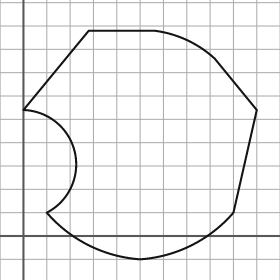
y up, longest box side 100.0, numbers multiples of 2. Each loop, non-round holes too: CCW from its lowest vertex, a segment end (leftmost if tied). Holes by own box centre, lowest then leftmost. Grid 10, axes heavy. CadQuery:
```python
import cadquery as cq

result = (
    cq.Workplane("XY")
    .moveTo(50.0, -10.0)
    .threePointArc((72.0, -4.0), (90.0, 10.0))
    .lineTo(100.0, 54.0)
    .lineTo(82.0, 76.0)
    .threePointArc((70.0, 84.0), (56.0, 88.0))
    .lineTo(28.0, 88.0)
    .lineTo(0.0, 54.0)
    .threePointArc((22.0, 36.0), (10.0, 10.0))
    .threePointArc((28.0, -4.0), (50.0, -10.0))
    .close()
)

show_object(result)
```